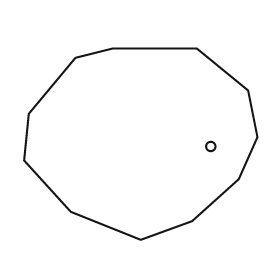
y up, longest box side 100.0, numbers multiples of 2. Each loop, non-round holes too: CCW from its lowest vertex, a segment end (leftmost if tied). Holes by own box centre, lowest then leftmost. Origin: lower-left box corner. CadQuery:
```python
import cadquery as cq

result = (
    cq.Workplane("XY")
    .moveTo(50.0, 0.0)
    .lineTo(72.0, 8.0)
    .lineTo(92.0, 26.0)
    .lineTo(100.0, 44.0)
    .lineTo(96.0, 64.0)
    .lineTo(74.0, 82.0)
    .lineTo(38.0, 82.0)
    .lineTo(22.0, 78.0)
    .lineTo(2.0, 54.0)
    .lineTo(0.0, 34.0)
    .lineTo(20.0, 12.0)
    .close()
    .moveTo(80.0, 40.0)
    .circle(2.0)
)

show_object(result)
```